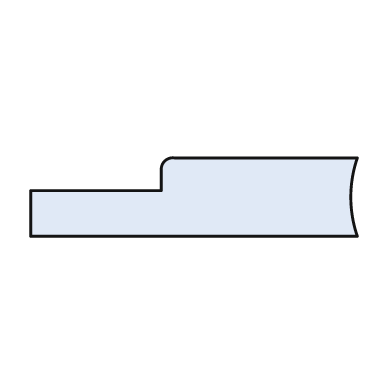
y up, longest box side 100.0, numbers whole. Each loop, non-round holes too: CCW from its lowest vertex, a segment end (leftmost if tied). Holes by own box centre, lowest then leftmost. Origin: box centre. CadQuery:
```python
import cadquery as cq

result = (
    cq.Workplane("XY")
    .moveTo(-50.0, -12.0)
    .lineTo(50.0, -12.0)
    .threePointArc((48.0, 0.0), (50.0, 12.0))
    .lineTo(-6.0, 12.0)
    .threePointArc((-9.0, 11.0), (-10.0, 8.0))
    .lineTo(-10.0, 2.0)
    .lineTo(-50.0, 2.0)
    .close()
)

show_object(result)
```